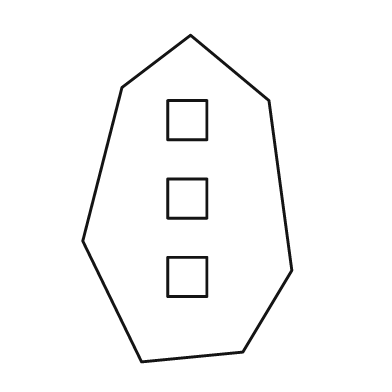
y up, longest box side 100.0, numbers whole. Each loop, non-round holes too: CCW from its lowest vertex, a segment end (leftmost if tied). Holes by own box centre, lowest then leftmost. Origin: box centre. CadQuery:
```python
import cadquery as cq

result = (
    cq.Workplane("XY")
    .moveTo(-14.0, -50.0)
    .lineTo(17.0, -47.0)
    .lineTo(32.0, -22.0)
    .lineTo(25.0, 30.0)
    .lineTo(1.0, 50.0)
    .lineTo(-20.0, 34.0)
    .lineTo(-32.0, -13.0)
    .close()
    .moveTo(-6.0, -30.0)
    .lineTo(6.0, -30.0)
    .lineTo(6.0, -18.0)
    .lineTo(-6.0, -18.0)
    .close()
    .moveTo(-6.0, -6.0)
    .lineTo(6.0, -6.0)
    .lineTo(6.0, 6.0)
    .lineTo(-6.0, 6.0)
    .close()
    .moveTo(-6.0, 18.0)
    .lineTo(6.0, 18.0)
    .lineTo(6.0, 30.0)
    .lineTo(-6.0, 30.0)
    .close()
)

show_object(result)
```